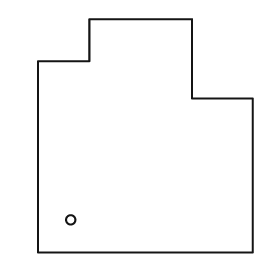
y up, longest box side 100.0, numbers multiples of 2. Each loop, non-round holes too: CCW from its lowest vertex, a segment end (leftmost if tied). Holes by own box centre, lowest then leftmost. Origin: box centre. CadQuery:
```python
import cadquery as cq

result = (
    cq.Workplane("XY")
    .moveTo(-46.0, -50.0)
    .lineTo(46.0, -50.0)
    .lineTo(46.0, 16.0)
    .lineTo(20.0, 16.0)
    .lineTo(20.0, 50.0)
    .lineTo(-24.0, 50.0)
    .lineTo(-24.0, 32.0)
    .lineTo(-46.0, 32.0)
    .close()
    .moveTo(-32.0, -36.0)
    .circle(2.0)
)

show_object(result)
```